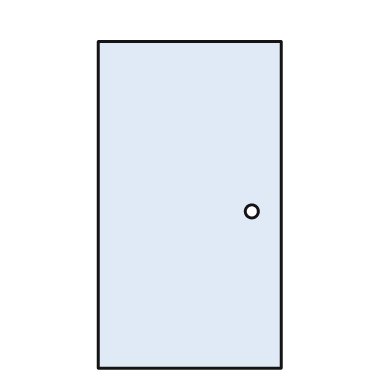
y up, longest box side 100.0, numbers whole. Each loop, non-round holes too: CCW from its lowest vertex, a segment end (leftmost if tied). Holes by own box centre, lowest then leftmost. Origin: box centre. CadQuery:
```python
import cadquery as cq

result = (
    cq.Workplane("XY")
    .moveTo(-28.0, -50.0)
    .lineTo(28.0, -50.0)
    .lineTo(28.0, 50.0)
    .lineTo(-28.0, 50.0)
    .close()
    .moveTo(19.0, -2.0)
    .circle(2.0)
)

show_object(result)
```